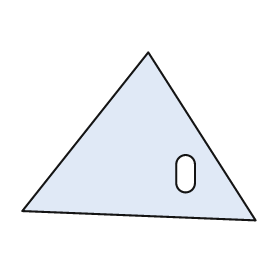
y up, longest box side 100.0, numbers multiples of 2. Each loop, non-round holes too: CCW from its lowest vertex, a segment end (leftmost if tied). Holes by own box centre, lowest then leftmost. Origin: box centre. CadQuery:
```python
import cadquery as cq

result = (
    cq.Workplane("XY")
    .moveTo(50.0, -36.0)
    .lineTo(4.0, 36.0)
    .lineTo(-50.0, -32.0)
    .close()
    .moveTo(16.0, -20.0)
    .threePointArc((20.0, -24.0), (24.0, -20.0))
    .lineTo(24.0, -12.0)
    .threePointArc((20.0, -8.0), (16.0, -12.0))
    .close()
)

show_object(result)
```